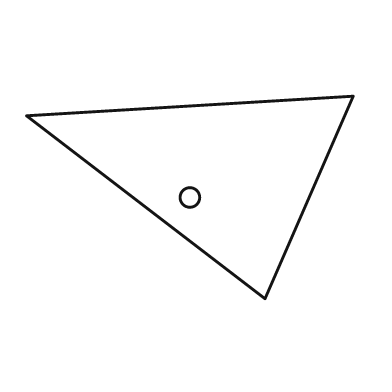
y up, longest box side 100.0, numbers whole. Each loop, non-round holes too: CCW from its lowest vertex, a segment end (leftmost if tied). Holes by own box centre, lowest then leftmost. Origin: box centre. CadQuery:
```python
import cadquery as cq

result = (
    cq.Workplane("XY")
    .moveTo(23.0, -31.0)
    .lineTo(50.0, 31.0)
    .lineTo(-50.0, 25.0)
    .close()
    .moveTo(0.0, 0.0)
    .circle(3.0)
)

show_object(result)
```